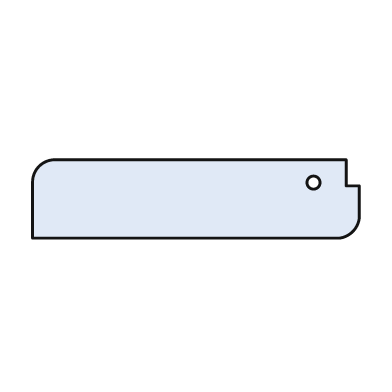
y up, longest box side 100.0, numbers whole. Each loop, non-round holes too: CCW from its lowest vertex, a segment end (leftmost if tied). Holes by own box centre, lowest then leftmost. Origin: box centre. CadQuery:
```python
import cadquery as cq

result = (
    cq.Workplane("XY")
    .moveTo(-50.0, -12.0)
    .lineTo(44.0, -12.0)
    .threePointArc((48.0, -10.0), (50.0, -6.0))
    .lineTo(50.0, 4.0)
    .lineTo(46.0, 4.0)
    .lineTo(46.0, 12.0)
    .lineTo(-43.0, 12.0)
    .threePointArc((-48.0, 10.0), (-50.0, 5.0))
    .close()
    .moveTo(36.0, 5.0)
    .circle(2.0)
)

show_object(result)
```